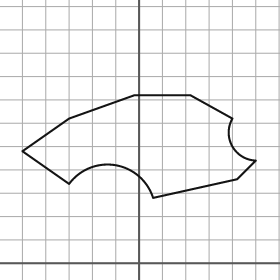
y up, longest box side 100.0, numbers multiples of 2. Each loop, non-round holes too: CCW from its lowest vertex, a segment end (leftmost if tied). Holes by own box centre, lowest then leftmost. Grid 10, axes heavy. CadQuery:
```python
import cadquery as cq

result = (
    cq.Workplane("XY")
    .moveTo(6.0, 28.0)
    .lineTo(42.0, 36.0)
    .lineTo(50.0, 44.0)
    .threePointArc((40.0, 50.0), (40.0, 62.0))
    .lineTo(22.0, 72.0)
    .lineTo(-2.0, 72.0)
    .lineTo(-30.0, 62.0)
    .lineTo(-50.0, 48.0)
    .lineTo(-30.0, 34.0)
    .threePointArc((-10.0, 42.0), (6.0, 28.0))
    .close()
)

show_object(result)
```